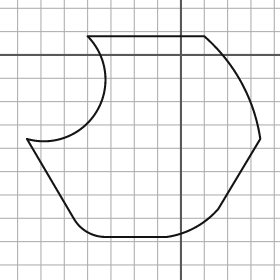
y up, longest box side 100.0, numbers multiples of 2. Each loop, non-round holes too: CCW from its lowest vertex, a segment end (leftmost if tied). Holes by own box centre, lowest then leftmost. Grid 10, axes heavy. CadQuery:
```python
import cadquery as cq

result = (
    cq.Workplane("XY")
    .moveTo(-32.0, -78.0)
    .lineTo(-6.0, -78.0)
    .threePointArc((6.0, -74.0), (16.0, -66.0))
    .lineTo(34.0, -36.0)
    .threePointArc((26.0, -12.0), (10.0, 8.0))
    .lineTo(-40.0, 8.0)
    .threePointArc((-36.0, -24.0), (-66.0, -36.0))
    .lineTo(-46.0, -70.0)
    .threePointArc((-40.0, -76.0), (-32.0, -78.0))
    .close()
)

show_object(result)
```